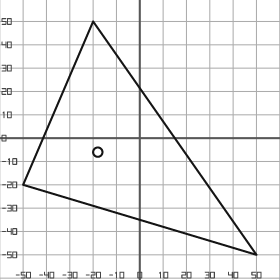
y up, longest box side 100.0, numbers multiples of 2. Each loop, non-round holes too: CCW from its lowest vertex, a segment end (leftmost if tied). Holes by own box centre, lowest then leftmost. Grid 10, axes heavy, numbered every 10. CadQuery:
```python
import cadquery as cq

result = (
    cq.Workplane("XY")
    .moveTo(50.0, -50.0)
    .lineTo(-20.0, 50.0)
    .lineTo(-50.0, -20.0)
    .close()
    .moveTo(-18.0, -6.0)
    .circle(2.0)
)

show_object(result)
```